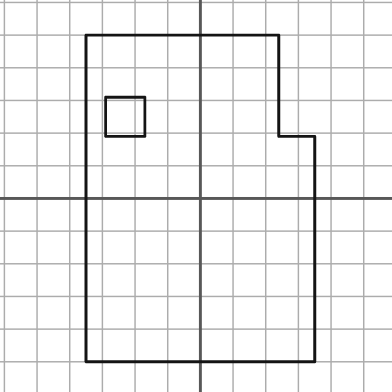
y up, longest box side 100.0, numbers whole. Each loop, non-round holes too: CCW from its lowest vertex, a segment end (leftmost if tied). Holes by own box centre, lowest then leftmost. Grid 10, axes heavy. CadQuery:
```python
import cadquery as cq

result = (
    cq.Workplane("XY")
    .moveTo(-35.0, -50.0)
    .lineTo(35.0, -50.0)
    .lineTo(35.0, 19.0)
    .lineTo(24.0, 19.0)
    .lineTo(24.0, 50.0)
    .lineTo(-35.0, 50.0)
    .close()
    .moveTo(-29.0, 19.0)
    .lineTo(-17.0, 19.0)
    .lineTo(-17.0, 31.0)
    .lineTo(-29.0, 31.0)
    .close()
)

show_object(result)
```